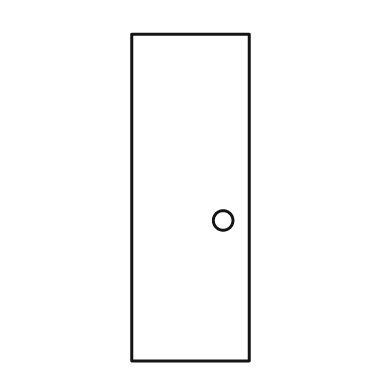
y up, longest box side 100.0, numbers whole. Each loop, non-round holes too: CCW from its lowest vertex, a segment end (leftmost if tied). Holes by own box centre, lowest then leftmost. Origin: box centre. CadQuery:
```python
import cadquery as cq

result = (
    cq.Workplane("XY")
    .moveTo(-18.0, -50.0)
    .lineTo(18.0, -50.0)
    .lineTo(18.0, 50.0)
    .lineTo(-18.0, 50.0)
    .close()
    .moveTo(10.0, -7.0)
    .circle(3.0)
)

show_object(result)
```